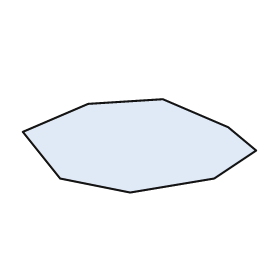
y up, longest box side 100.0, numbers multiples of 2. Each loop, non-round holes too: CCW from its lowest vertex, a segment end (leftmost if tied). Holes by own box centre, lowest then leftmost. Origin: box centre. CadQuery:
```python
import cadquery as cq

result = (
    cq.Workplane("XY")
    .moveTo(-4.0, -20.0)
    .lineTo(32.0, -14.0)
    .lineTo(50.0, -2.0)
    .lineTo(38.0, 8.0)
    .lineTo(10.0, 20.0)
    .lineTo(-22.0, 18.0)
    .lineTo(-50.0, 6.0)
    .lineTo(-34.0, -14.0)
    .close()
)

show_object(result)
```